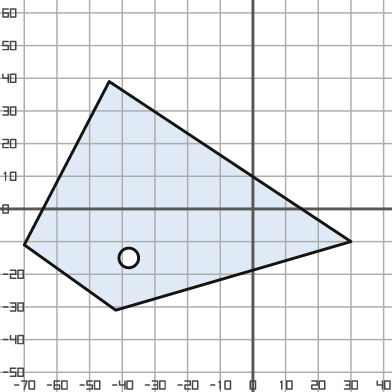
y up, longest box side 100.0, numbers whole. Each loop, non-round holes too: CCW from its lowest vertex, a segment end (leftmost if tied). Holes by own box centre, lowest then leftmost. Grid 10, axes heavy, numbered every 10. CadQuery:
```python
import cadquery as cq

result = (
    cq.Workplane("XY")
    .moveTo(-42.0, -31.0)
    .lineTo(30.0, -10.0)
    .lineTo(-44.0, 39.0)
    .lineTo(-70.0, -11.0)
    .close()
    .moveTo(-38.0, -15.0)
    .circle(3.0)
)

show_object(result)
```